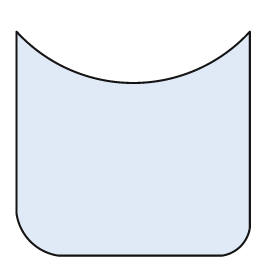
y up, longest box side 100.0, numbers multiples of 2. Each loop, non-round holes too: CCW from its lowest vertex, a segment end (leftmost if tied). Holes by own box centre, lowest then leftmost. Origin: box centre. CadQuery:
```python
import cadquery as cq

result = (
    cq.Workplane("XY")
    .moveTo(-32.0, -48.0)
    .lineTo(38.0, -48.0)
    .threePointArc((46.0, -44.0), (50.0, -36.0))
    .lineTo(50.0, 48.0)
    .threePointArc((0.0, 26.0), (-50.0, 48.0))
    .lineTo(-50.0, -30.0)
    .threePointArc((-44.0, -42.0), (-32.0, -48.0))
    .close()
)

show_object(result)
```